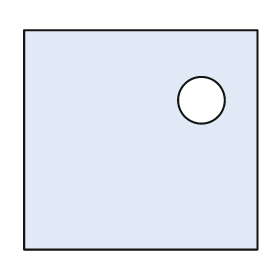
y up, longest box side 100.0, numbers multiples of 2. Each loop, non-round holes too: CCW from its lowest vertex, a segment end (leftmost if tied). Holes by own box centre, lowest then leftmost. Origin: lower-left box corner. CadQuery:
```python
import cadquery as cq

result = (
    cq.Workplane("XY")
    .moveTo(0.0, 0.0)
    .lineTo(100.0, 0.0)
    .lineTo(100.0, 94.0)
    .lineTo(0.0, 94.0)
    .close()
    .moveTo(76.0, 64.0)
    .circle(10.0)
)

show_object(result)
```